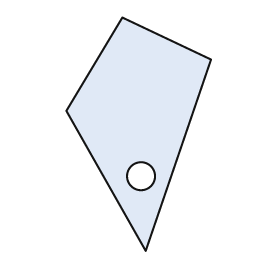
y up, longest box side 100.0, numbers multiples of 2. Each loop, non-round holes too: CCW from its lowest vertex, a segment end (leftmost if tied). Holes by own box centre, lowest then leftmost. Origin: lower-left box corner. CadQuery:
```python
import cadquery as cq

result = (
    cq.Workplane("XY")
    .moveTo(34.0, 0.0)
    .lineTo(62.0, 82.0)
    .lineTo(24.0, 100.0)
    .lineTo(0.0, 60.0)
    .close()
    .moveTo(32.0, 32.0)
    .circle(6.0)
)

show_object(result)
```